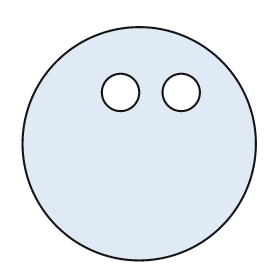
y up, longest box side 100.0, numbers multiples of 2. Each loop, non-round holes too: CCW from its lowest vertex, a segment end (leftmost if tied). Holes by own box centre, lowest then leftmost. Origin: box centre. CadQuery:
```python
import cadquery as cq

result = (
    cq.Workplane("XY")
    .moveTo(0.0, 0.0)
    .circle(50.0)
    .moveTo(-8.0, 22.0)
    .circle(8.0)
    .moveTo(18.0, 22.0)
    .circle(8.0)
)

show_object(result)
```